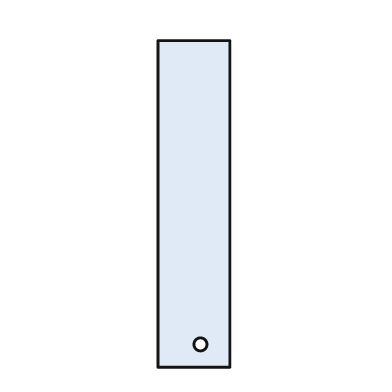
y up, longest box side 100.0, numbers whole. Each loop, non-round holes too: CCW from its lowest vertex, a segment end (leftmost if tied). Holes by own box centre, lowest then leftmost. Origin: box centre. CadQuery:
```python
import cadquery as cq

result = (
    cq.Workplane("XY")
    .moveTo(-11.0, -50.0)
    .lineTo(11.0, -50.0)
    .lineTo(11.0, 50.0)
    .lineTo(-11.0, 50.0)
    .close()
    .moveTo(2.0, -43.0)
    .circle(2.0)
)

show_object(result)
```